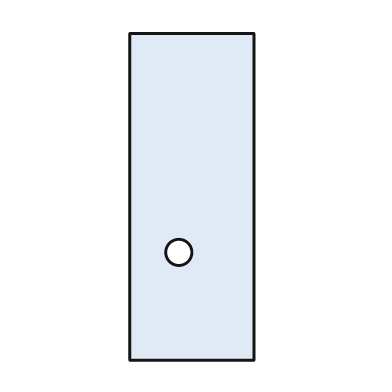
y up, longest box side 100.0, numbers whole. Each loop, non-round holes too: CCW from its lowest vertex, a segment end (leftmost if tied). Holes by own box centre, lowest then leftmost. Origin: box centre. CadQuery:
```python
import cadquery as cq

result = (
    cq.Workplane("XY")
    .moveTo(-19.0, -50.0)
    .lineTo(19.0, -50.0)
    .lineTo(19.0, 50.0)
    .lineTo(-19.0, 50.0)
    .close()
    .moveTo(-4.0, -17.0)
    .circle(4.0)
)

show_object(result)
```